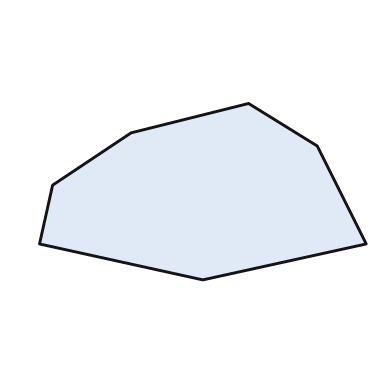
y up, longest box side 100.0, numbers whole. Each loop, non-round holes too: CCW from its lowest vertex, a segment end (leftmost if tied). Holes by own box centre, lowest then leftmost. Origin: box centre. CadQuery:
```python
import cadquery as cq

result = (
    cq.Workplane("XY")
    .moveTo(0.0, -27.0)
    .lineTo(50.0, -16.0)
    .lineTo(35.0, 14.0)
    .lineTo(14.0, 27.0)
    .lineTo(-22.0, 18.0)
    .lineTo(-46.0, 2.0)
    .lineTo(-50.0, -16.0)
    .close()
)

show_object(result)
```